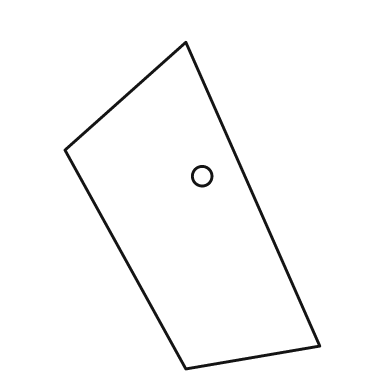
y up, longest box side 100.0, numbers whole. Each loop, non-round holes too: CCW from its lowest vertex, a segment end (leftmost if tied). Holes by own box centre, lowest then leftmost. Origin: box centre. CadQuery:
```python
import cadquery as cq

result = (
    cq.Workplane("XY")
    .moveTo(-2.0, -50.0)
    .lineTo(39.0, -43.0)
    .lineTo(-2.0, 50.0)
    .lineTo(-39.0, 17.0)
    .close()
    .moveTo(3.0, 9.0)
    .circle(3.0)
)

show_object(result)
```